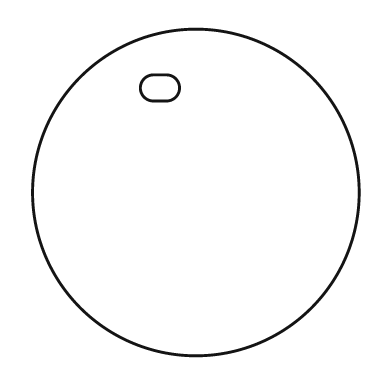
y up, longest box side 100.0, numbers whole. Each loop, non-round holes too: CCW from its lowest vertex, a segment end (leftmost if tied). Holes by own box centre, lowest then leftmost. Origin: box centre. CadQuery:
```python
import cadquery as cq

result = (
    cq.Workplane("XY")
    .moveTo(0.0, 0.0)
    .circle(50.0)
    .moveTo(-13.0, 28.0)
    .lineTo(-9.0, 28.0)
    .threePointArc((-5.0, 32.0), (-9.0, 36.0))
    .lineTo(-13.0, 36.0)
    .threePointArc((-17.0, 32.0), (-13.0, 28.0))
    .close()
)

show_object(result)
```